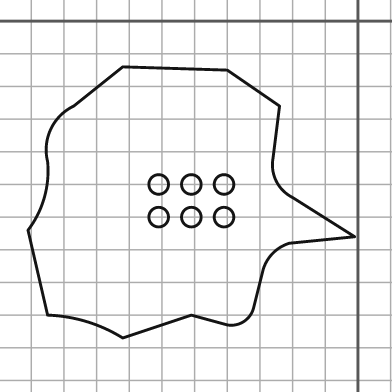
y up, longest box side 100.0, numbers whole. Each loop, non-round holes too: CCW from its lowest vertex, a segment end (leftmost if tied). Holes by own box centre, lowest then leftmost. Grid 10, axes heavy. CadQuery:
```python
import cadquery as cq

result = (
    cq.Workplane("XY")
    .moveTo(-72.0, -97.0)
    .lineTo(-51.0, -90.0)
    .lineTo(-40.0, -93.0)
    .threePointArc((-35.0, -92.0), (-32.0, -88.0))
    .lineTo(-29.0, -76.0)
    .threePointArc((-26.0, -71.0), (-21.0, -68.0))
    .lineTo(-1.0, -66.0)
    .lineTo(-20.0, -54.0)
    .threePointArc((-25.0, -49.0), (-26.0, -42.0))
    .lineTo(-24.0, -26.0)
    .lineTo(-40.0, -15.0)
    .lineTo(-72.0, -14.0)
    .lineTo(-87.0, -26.0)
    .threePointArc((-94.0, -33.0), (-95.0, -43.0))
    .threePointArc((-96.0, -54.0), (-101.0, -64.0))
    .lineTo(-95.0, -90.0)
    .threePointArc((-83.0, -92.0), (-72.0, -97.0))
    .close()
    .moveTo(-61.0, -60.0)
    .circle(3.0)
    .moveTo(-51.0, -60.0)
    .circle(3.0)
    .moveTo(-41.0, -60.0)
    .circle(3.0)
    .moveTo(-61.0, -50.0)
    .circle(3.0)
    .moveTo(-51.0, -50.0)
    .circle(3.0)
    .moveTo(-41.0, -50.0)
    .circle(3.0)
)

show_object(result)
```